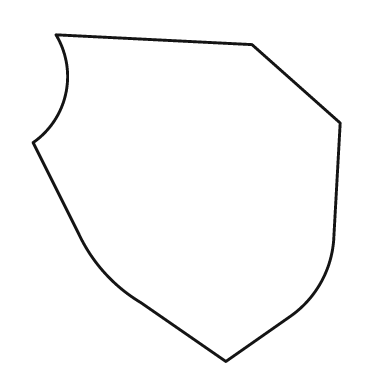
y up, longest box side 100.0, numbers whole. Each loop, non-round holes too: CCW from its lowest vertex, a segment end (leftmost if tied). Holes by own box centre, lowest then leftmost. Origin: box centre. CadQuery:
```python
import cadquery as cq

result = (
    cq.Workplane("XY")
    .moveTo(12.0, -50.0)
    .lineTo(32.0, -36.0)
    .threePointArc((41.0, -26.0), (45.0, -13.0))
    .lineTo(47.0, 23.0)
    .lineTo(20.0, 47.0)
    .lineTo(-40.0, 50.0)
    .threePointArc((-37.0, 32.0), (-47.0, 17.0))
    .lineTo(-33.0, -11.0)
    .threePointArc((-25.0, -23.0), (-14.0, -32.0))
    .close()
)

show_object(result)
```